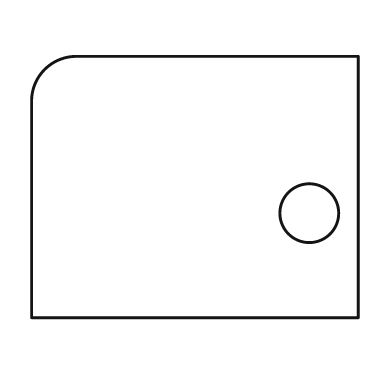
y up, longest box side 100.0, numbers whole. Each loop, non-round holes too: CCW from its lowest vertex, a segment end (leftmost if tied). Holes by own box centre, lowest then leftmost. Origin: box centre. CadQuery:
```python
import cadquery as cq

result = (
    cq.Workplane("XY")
    .moveTo(-50.0, -40.0)
    .lineTo(50.0, -40.0)
    .lineTo(50.0, 40.0)
    .lineTo(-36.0, 40.0)
    .threePointArc((-46.0, 36.0), (-50.0, 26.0))
    .close()
    .moveTo(35.0, -8.0)
    .circle(9.0)
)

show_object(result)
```